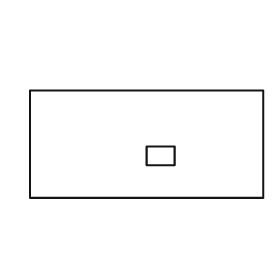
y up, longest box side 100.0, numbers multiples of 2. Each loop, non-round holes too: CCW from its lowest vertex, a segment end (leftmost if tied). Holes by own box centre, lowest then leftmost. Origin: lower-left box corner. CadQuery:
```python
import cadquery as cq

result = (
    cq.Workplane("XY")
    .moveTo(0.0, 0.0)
    .lineTo(100.0, 0.0)
    .lineTo(100.0, 46.0)
    .lineTo(0.0, 46.0)
    .close()
    .moveTo(50.0, 14.0)
    .lineTo(62.0, 14.0)
    .lineTo(62.0, 22.0)
    .lineTo(50.0, 22.0)
    .close()
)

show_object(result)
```